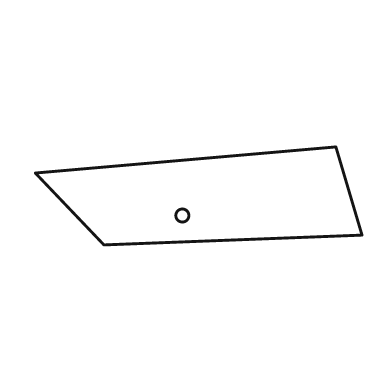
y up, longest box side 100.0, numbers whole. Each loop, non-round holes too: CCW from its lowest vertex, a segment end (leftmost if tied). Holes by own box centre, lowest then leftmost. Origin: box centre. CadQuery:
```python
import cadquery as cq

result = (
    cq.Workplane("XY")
    .moveTo(-29.0, -15.0)
    .lineTo(50.0, -12.0)
    .lineTo(42.0, 15.0)
    .lineTo(-50.0, 7.0)
    .close()
    .moveTo(-5.0, -6.0)
    .circle(2.0)
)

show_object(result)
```